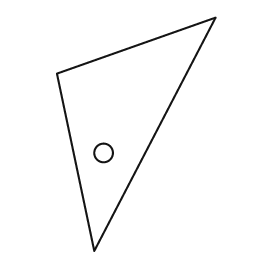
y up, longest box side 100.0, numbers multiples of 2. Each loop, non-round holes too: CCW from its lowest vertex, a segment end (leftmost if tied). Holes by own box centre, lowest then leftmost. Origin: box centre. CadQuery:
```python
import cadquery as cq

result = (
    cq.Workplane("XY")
    .moveTo(-18.0, -50.0)
    .lineTo(34.0, 50.0)
    .lineTo(-34.0, 26.0)
    .close()
    .moveTo(-14.0, -8.0)
    .circle(4.0)
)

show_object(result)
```